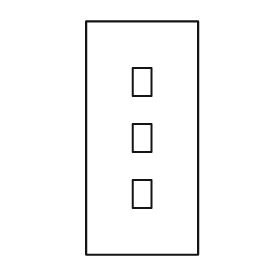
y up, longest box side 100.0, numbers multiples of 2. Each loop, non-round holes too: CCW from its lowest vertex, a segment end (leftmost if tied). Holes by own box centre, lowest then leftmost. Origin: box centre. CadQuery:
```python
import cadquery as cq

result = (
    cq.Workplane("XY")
    .moveTo(-24.0, -50.0)
    .lineTo(24.0, -50.0)
    .lineTo(24.0, 50.0)
    .lineTo(-24.0, 50.0)
    .close()
    .moveTo(-4.0, -30.0)
    .lineTo(4.0, -30.0)
    .lineTo(4.0, -18.0)
    .lineTo(-4.0, -18.0)
    .close()
    .moveTo(-4.0, -6.0)
    .lineTo(4.0, -6.0)
    .lineTo(4.0, 6.0)
    .lineTo(-4.0, 6.0)
    .close()
    .moveTo(-4.0, 18.0)
    .lineTo(4.0, 18.0)
    .lineTo(4.0, 30.0)
    .lineTo(-4.0, 30.0)
    .close()
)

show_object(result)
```